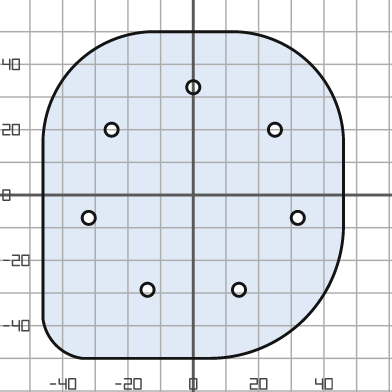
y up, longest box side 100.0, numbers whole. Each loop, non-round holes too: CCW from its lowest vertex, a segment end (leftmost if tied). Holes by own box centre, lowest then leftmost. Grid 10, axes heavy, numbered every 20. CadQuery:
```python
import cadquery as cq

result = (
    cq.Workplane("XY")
    .moveTo(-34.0, -50.0)
    .lineTo(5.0, -50.0)
    .threePointArc((34.0, -38.0), (46.0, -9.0))
    .lineTo(46.0, 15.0)
    .threePointArc((36.0, 40.0), (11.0, 50.0))
    .lineTo(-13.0, 50.0)
    .threePointArc((-36.0, 40.0), (-46.0, 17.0))
    .lineTo(-46.0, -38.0)
    .threePointArc((-42.0, -46.0), (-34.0, -50.0))
    .close()
    .moveTo(-14.0, -29.0)
    .circle(2.0)
    .moveTo(14.0, -29.0)
    .circle(2.0)
    .moveTo(-32.0, -7.0)
    .circle(2.0)
    .moveTo(32.0, -7.0)
    .circle(2.0)
    .moveTo(-25.0, 20.0)
    .circle(2.0)
    .moveTo(25.0, 20.0)
    .circle(2.0)
    .moveTo(0.0, 33.0)
    .circle(2.0)
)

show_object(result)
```